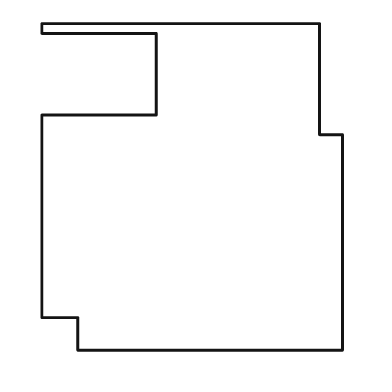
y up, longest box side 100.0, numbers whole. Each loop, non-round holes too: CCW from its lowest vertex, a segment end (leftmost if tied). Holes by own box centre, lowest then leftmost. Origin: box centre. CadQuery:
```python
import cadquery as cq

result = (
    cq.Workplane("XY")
    .moveTo(-35.0, -50.0)
    .lineTo(46.0, -50.0)
    .lineTo(46.0, 16.0)
    .lineTo(39.0, 16.0)
    .lineTo(39.0, 50.0)
    .lineTo(-46.0, 50.0)
    .lineTo(-46.0, 47.0)
    .lineTo(-11.0, 47.0)
    .lineTo(-11.0, 22.0)
    .lineTo(-46.0, 22.0)
    .lineTo(-46.0, -40.0)
    .lineTo(-35.0, -40.0)
    .close()
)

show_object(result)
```